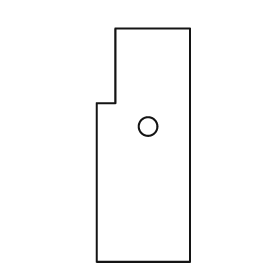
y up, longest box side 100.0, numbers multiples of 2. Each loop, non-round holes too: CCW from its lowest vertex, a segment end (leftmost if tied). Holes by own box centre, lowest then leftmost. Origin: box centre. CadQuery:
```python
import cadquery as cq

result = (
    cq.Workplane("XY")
    .moveTo(-20.0, -50.0)
    .lineTo(20.0, -50.0)
    .lineTo(20.0, 50.0)
    .lineTo(-12.0, 50.0)
    .lineTo(-12.0, 18.0)
    .lineTo(-20.0, 18.0)
    .close()
    .moveTo(2.0, 8.0)
    .circle(4.0)
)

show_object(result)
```